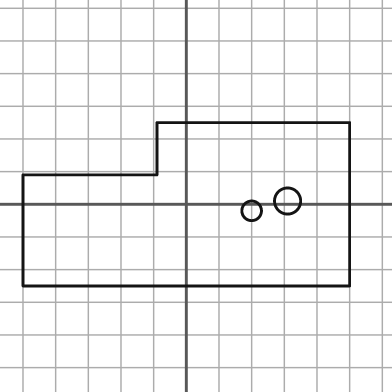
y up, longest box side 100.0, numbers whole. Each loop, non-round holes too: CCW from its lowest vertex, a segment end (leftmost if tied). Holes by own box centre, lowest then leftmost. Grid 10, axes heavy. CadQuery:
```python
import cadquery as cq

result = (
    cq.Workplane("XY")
    .moveTo(-50.0, -25.0)
    .lineTo(50.0, -25.0)
    .lineTo(50.0, 25.0)
    .lineTo(-9.0, 25.0)
    .lineTo(-9.0, 9.0)
    .lineTo(-50.0, 9.0)
    .close()
    .moveTo(20.0, -2.0)
    .circle(3.0)
    .moveTo(31.0, 1.0)
    .circle(4.0)
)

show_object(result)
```